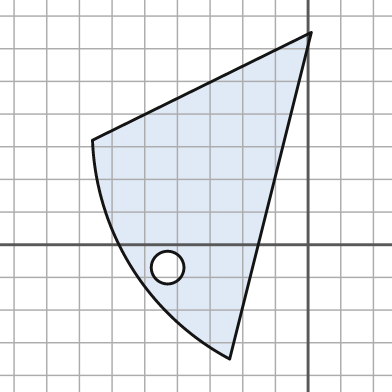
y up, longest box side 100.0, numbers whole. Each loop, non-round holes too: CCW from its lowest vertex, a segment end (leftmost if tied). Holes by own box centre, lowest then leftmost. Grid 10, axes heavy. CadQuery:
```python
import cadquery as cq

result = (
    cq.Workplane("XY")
    .moveTo(-24.0, -35.0)
    .lineTo(1.0, 65.0)
    .lineTo(-66.0, 32.0)
    .threePointArc((-54.0, -7.0), (-24.0, -35.0))
    .close()
    .moveTo(-43.0, -7.0)
    .circle(5.0)
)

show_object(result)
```